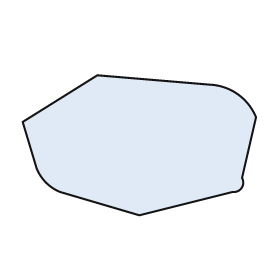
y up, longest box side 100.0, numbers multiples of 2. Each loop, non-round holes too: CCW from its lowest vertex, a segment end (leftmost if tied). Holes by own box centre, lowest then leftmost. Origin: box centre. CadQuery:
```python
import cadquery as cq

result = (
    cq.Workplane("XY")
    .moveTo(0.0, -30.0)
    .lineTo(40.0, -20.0)
    .threePointArc((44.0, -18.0), (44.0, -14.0))
    .lineTo(50.0, 12.0)
    .threePointArc((42.0, 22.0), (30.0, 26.0))
    .lineTo(-18.0, 30.0)
    .lineTo(-50.0, 10.0)
    .lineTo(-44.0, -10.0)
    .threePointArc((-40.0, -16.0), (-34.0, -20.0))
    .close()
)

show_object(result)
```